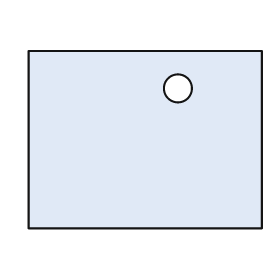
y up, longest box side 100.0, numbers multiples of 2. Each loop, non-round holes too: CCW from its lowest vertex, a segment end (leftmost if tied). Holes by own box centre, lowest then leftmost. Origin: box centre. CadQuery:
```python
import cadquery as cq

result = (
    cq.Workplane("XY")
    .moveTo(-50.0, -38.0)
    .lineTo(50.0, -38.0)
    .lineTo(50.0, 38.0)
    .lineTo(-50.0, 38.0)
    .close()
    .moveTo(14.0, 22.0)
    .circle(6.0)
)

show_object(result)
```